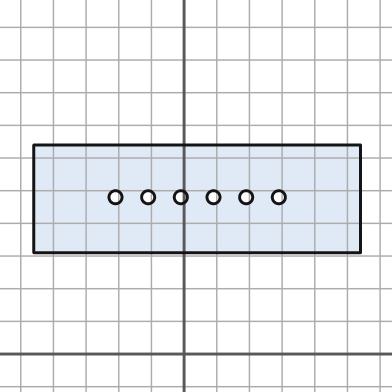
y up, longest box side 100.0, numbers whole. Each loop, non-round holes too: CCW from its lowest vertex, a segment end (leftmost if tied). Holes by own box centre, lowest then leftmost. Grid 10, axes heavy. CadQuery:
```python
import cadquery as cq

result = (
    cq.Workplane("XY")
    .moveTo(-46.0, 31.0)
    .lineTo(54.0, 31.0)
    .lineTo(54.0, 64.0)
    .lineTo(-46.0, 64.0)
    .close()
    .moveTo(-21.0, 48.0)
    .circle(2.0)
    .moveTo(-11.0, 48.0)
    .circle(2.0)
    .moveTo(-1.0, 48.0)
    .circle(2.0)
    .moveTo(9.0, 48.0)
    .circle(2.0)
    .moveTo(19.0, 48.0)
    .circle(2.0)
    .moveTo(29.0, 48.0)
    .circle(2.0)
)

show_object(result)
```